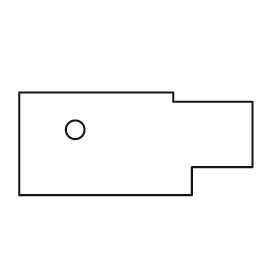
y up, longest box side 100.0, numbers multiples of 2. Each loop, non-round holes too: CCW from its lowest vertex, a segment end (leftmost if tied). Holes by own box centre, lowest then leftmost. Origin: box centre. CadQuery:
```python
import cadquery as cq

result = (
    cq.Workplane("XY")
    .moveTo(-50.0, -22.0)
    .lineTo(24.0, -22.0)
    .lineTo(24.0, -10.0)
    .lineTo(50.0, -10.0)
    .lineTo(50.0, 18.0)
    .lineTo(16.0, 18.0)
    .lineTo(16.0, 22.0)
    .lineTo(-50.0, 22.0)
    .close()
    .moveTo(-26.0, 6.0)
    .circle(4.0)
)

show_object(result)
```